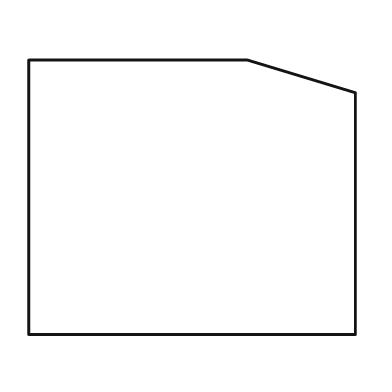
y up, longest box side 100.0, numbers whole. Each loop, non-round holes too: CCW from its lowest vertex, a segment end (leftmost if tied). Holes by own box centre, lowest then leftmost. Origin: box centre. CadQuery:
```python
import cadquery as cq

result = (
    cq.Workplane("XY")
    .moveTo(-50.0, -42.0)
    .lineTo(50.0, -42.0)
    .lineTo(50.0, 32.0)
    .lineTo(17.0, 42.0)
    .lineTo(-50.0, 42.0)
    .close()
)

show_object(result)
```